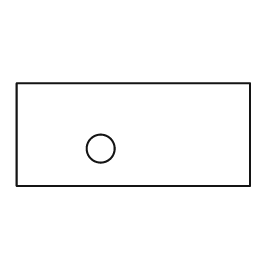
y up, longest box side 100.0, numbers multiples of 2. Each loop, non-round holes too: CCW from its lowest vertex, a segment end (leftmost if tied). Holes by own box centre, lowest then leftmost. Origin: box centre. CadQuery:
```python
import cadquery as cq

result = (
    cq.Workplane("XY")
    .moveTo(-50.0, -22.0)
    .lineTo(50.0, -22.0)
    .lineTo(50.0, 22.0)
    .lineTo(-50.0, 22.0)
    .close()
    .moveTo(-14.0, -6.0)
    .circle(6.0)
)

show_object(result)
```